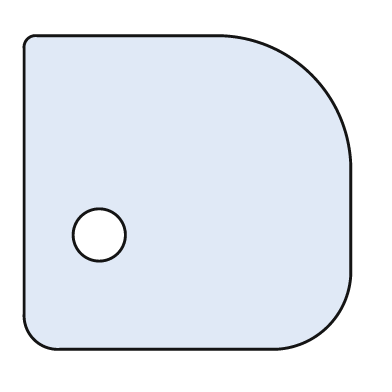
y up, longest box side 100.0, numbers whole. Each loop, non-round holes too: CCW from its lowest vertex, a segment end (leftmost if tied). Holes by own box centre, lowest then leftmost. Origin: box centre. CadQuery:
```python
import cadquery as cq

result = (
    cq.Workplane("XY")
    .moveTo(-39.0, -48.0)
    .lineTo(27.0, -48.0)
    .threePointArc((43.0, -41.0), (50.0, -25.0))
    .lineTo(50.0, 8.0)
    .threePointArc((38.0, 36.0), (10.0, 48.0))
    .lineTo(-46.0, 48.0)
    .threePointArc((-49.0, 47.0), (-50.0, 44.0))
    .lineTo(-50.0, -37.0)
    .threePointArc((-47.0, -45.0), (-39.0, -48.0))
    .close()
    .moveTo(-27.0, -13.0)
    .circle(8.0)
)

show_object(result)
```